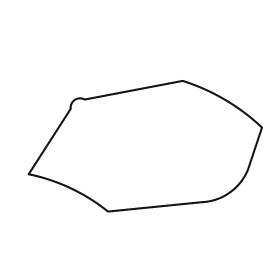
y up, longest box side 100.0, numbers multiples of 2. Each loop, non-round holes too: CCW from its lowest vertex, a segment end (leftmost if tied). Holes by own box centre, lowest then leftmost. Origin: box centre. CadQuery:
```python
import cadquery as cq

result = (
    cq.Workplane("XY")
    .moveTo(-16.0, -28.0)
    .lineTo(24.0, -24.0)
    .threePointArc((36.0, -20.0), (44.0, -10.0))
    .lineTo(50.0, 8.0)
    .threePointArc((34.0, 20.0), (16.0, 28.0))
    .lineTo(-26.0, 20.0)
    .threePointArc((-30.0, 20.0), (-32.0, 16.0))
    .lineTo(-50.0, -12.0)
    .threePointArc((-32.0, -18.0), (-16.0, -28.0))
    .close()
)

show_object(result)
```